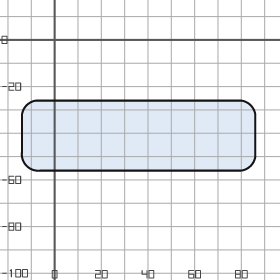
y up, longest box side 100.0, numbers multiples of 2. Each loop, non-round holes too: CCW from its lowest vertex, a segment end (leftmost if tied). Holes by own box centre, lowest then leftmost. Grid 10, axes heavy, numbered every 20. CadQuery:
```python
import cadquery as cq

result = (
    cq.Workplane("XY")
    .moveTo(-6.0, -56.0)
    .lineTo(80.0, -56.0)
    .threePointArc((84.0, -54.0), (86.0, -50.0))
    .lineTo(86.0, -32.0)
    .threePointArc((84.0, -28.0), (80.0, -26.0))
    .lineTo(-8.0, -26.0)
    .threePointArc((-12.0, -28.0), (-14.0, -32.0))
    .lineTo(-14.0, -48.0)
    .threePointArc((-12.0, -54.0), (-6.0, -56.0))
    .close()
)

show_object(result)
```